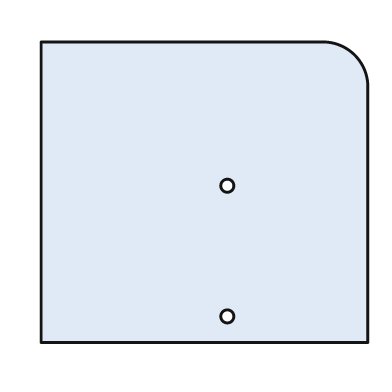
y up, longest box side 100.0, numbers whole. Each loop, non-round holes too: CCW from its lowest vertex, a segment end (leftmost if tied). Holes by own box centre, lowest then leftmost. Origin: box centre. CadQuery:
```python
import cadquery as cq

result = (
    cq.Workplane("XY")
    .moveTo(-50.0, -46.0)
    .lineTo(50.0, -46.0)
    .lineTo(50.0, 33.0)
    .threePointArc((46.0, 42.0), (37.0, 46.0))
    .lineTo(-50.0, 46.0)
    .close()
    .moveTo(7.0, -38.0)
    .circle(2.0)
    .moveTo(7.0, 2.0)
    .circle(2.0)
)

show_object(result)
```